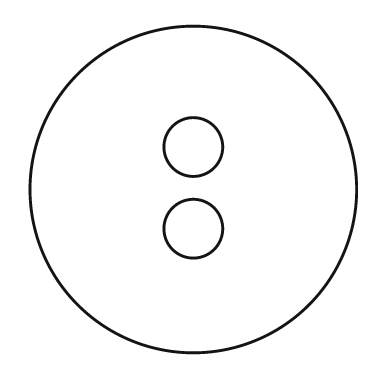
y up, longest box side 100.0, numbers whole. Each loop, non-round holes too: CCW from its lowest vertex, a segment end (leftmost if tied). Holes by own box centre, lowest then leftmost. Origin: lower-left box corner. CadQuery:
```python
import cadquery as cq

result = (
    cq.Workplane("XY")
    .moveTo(50.0, 50.0)
    .circle(50.0)
    .moveTo(50.0, 38.0)
    .circle(9.0)
    .moveTo(50.0, 63.0)
    .circle(9.0)
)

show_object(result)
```